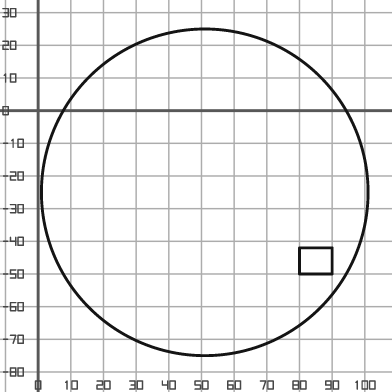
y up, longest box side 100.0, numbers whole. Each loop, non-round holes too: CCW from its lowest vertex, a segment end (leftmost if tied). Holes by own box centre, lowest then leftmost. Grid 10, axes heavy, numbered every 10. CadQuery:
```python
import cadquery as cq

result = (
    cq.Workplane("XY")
    .moveTo(51.0, -25.0)
    .circle(50.0)
    .moveTo(80.0, -50.0)
    .lineTo(90.0, -50.0)
    .lineTo(90.0, -42.0)
    .lineTo(80.0, -42.0)
    .close()
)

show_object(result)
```